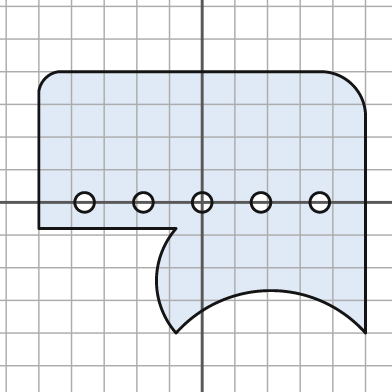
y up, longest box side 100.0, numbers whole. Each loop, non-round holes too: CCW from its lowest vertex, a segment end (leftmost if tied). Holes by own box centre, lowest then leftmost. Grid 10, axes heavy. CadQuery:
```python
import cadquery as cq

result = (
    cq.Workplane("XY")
    .moveTo(-8.0, -40.0)
    .threePointArc((21.0, -27.0), (50.0, -40.0))
    .lineTo(50.0, 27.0)
    .threePointArc((46.0, 36.0), (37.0, 40.0))
    .lineTo(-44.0, 40.0)
    .threePointArc((-48.0, 38.0), (-50.0, 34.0))
    .lineTo(-50.0, -8.0)
    .lineTo(-8.0, -8.0)
    .threePointArc((-14.0, -24.0), (-8.0, -40.0))
    .close()
    .moveTo(-36.0, 0.0)
    .circle(3.0)
    .moveTo(-18.0, 0.0)
    .circle(3.0)
    .moveTo(0.0, 0.0)
    .circle(3.0)
    .moveTo(18.0, 0.0)
    .circle(3.0)
    .moveTo(36.0, 0.0)
    .circle(3.0)
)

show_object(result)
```